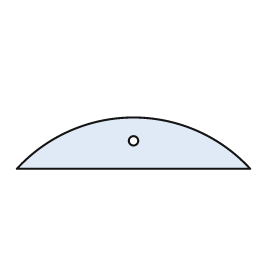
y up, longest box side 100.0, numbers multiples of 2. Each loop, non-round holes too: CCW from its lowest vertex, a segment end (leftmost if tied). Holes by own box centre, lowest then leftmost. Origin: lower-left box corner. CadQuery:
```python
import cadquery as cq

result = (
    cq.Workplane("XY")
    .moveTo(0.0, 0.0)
    .lineTo(100.0, 0.0)
    .threePointArc((50.0, 22.0), (0.0, 0.0))
    .close()
    .moveTo(50.0, 12.0)
    .circle(2.0)
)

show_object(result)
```